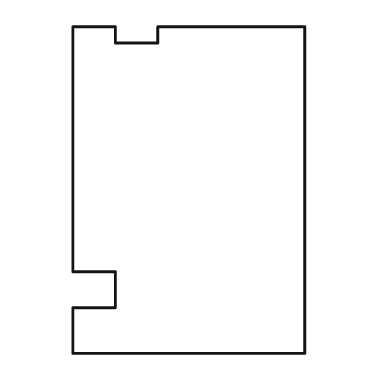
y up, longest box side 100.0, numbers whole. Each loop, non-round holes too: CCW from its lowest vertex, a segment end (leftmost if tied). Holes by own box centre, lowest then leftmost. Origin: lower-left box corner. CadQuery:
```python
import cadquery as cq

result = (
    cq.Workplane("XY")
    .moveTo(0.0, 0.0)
    .lineTo(71.0, 0.0)
    .lineTo(71.0, 100.0)
    .lineTo(26.0, 100.0)
    .lineTo(26.0, 95.0)
    .lineTo(13.0, 95.0)
    .lineTo(13.0, 100.0)
    .lineTo(0.0, 100.0)
    .lineTo(0.0, 25.0)
    .lineTo(13.0, 25.0)
    .lineTo(13.0, 14.0)
    .lineTo(0.0, 14.0)
    .close()
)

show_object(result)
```